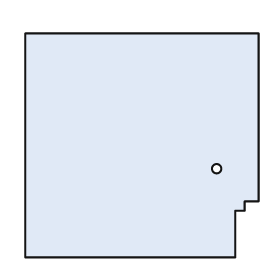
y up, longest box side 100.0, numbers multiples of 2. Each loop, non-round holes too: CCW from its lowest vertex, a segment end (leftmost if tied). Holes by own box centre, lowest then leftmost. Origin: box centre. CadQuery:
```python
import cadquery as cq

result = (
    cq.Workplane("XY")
    .moveTo(-50.0, -48.0)
    .lineTo(40.0, -48.0)
    .lineTo(40.0, -28.0)
    .lineTo(44.0, -28.0)
    .lineTo(44.0, -24.0)
    .lineTo(50.0, -24.0)
    .lineTo(50.0, 48.0)
    .lineTo(-50.0, 48.0)
    .close()
    .moveTo(32.0, -10.0)
    .circle(2.0)
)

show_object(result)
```